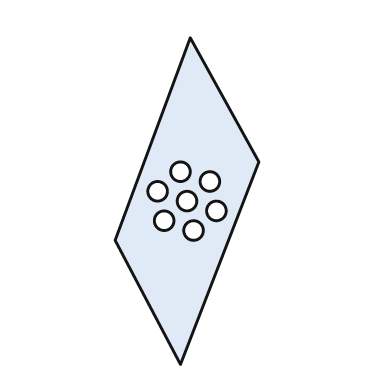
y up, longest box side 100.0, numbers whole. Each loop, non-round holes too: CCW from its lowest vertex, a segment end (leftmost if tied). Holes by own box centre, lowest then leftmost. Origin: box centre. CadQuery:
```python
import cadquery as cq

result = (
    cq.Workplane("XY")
    .moveTo(-2.0, -50.0)
    .lineTo(22.0, 12.0)
    .lineTo(1.0, 50.0)
    .lineTo(-22.0, -12.0)
    .close()
    .moveTo(2.0, -9.0)
    .circle(3.0)
    .moveTo(-7.0, -6.0)
    .circle(3.0)
    .moveTo(9.0, -3.0)
    .circle(3.0)
    .moveTo(0.0, 0.0)
    .circle(3.0)
    .moveTo(-9.0, 3.0)
    .circle(3.0)
    .moveTo(7.0, 6.0)
    .circle(3.0)
    .moveTo(-2.0, 9.0)
    .circle(3.0)
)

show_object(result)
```